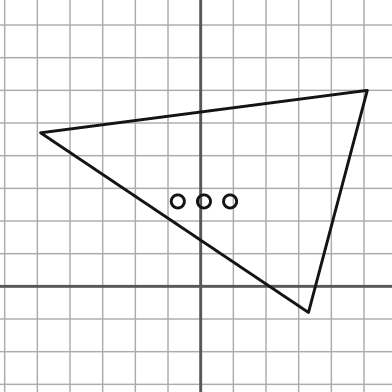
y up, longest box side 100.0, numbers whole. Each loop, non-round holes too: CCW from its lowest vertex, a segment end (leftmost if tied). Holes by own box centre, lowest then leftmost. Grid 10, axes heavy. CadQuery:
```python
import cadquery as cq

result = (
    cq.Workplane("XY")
    .moveTo(33.0, -8.0)
    .lineTo(51.0, 60.0)
    .lineTo(-49.0, 47.0)
    .close()
    .moveTo(-7.0, 26.0)
    .circle(2.0)
    .moveTo(1.0, 26.0)
    .circle(2.0)
    .moveTo(9.0, 26.0)
    .circle(2.0)
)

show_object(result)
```